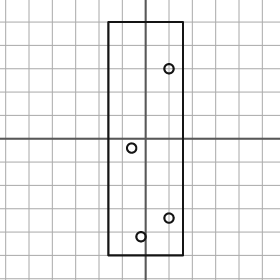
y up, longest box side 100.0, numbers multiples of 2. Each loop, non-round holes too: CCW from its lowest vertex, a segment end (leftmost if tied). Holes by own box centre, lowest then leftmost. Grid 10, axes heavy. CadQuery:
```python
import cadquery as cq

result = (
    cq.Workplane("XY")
    .moveTo(-16.0, -50.0)
    .lineTo(16.0, -50.0)
    .lineTo(16.0, 50.0)
    .lineTo(-16.0, 50.0)
    .close()
    .moveTo(-2.0, -42.0)
    .circle(2.0)
    .moveTo(10.0, -34.0)
    .circle(2.0)
    .moveTo(-6.0, -4.0)
    .circle(2.0)
    .moveTo(10.0, 30.0)
    .circle(2.0)
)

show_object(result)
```